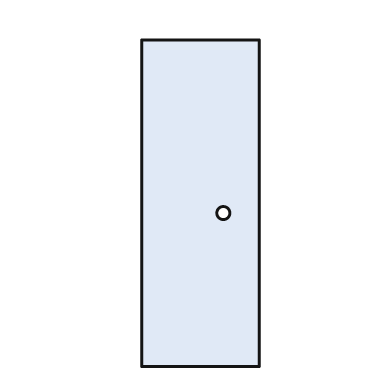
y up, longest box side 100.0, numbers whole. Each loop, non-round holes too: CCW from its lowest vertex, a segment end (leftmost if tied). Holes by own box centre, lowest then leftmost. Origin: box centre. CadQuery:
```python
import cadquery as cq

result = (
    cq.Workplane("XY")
    .moveTo(-18.0, -50.0)
    .lineTo(18.0, -50.0)
    .lineTo(18.0, 50.0)
    .lineTo(-18.0, 50.0)
    .close()
    .moveTo(7.0, -3.0)
    .circle(2.0)
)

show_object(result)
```